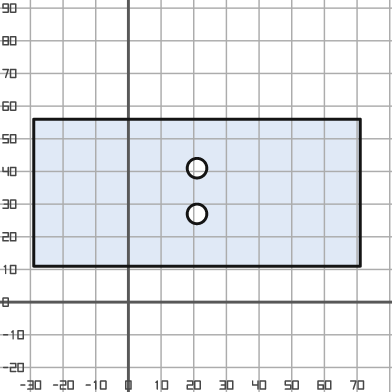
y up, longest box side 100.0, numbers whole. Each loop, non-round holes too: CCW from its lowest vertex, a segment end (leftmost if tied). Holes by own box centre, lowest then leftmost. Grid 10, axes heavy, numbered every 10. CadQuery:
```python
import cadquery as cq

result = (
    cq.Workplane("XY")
    .moveTo(-29.0, 11.0)
    .lineTo(71.0, 11.0)
    .lineTo(71.0, 56.0)
    .lineTo(-29.0, 56.0)
    .close()
    .moveTo(21.0, 27.0)
    .circle(3.0)
    .moveTo(21.0, 41.0)
    .circle(3.0)
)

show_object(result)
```